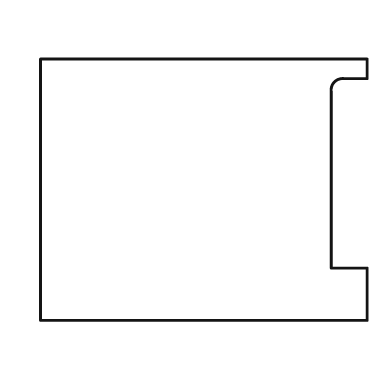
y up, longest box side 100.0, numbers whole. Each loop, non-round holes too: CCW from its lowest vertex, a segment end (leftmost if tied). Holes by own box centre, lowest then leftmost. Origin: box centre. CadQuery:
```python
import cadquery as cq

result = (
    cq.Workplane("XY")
    .moveTo(-50.0, -40.0)
    .lineTo(50.0, -40.0)
    .lineTo(50.0, -24.0)
    .lineTo(39.0, -24.0)
    .lineTo(39.0, 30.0)
    .threePointArc((40.0, 33.0), (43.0, 34.0))
    .lineTo(50.0, 34.0)
    .lineTo(50.0, 40.0)
    .lineTo(-50.0, 40.0)
    .close()
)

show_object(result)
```